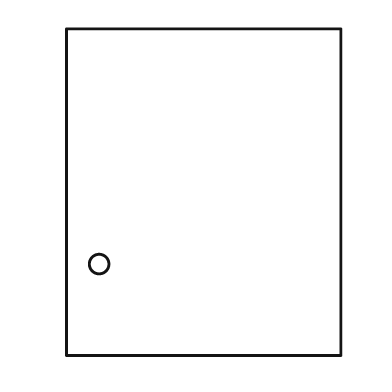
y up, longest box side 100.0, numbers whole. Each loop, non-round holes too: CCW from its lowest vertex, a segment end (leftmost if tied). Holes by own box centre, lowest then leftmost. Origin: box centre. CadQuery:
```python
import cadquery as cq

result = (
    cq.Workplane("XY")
    .moveTo(-42.0, -50.0)
    .lineTo(42.0, -50.0)
    .lineTo(42.0, 50.0)
    .lineTo(-42.0, 50.0)
    .close()
    .moveTo(-32.0, -22.0)
    .circle(3.0)
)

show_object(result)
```